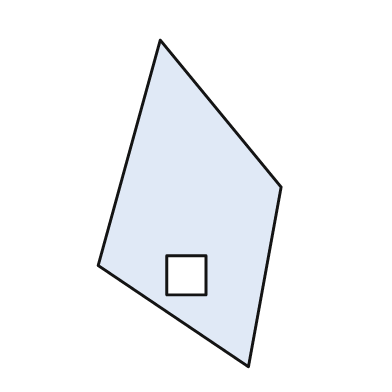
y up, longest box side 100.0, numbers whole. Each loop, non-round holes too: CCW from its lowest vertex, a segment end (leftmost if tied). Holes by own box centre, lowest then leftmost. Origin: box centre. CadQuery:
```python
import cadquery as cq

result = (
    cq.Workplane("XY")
    .moveTo(18.0, -50.0)
    .lineTo(28.0, 5.0)
    .lineTo(-9.0, 50.0)
    .lineTo(-28.0, -19.0)
    .close()
    .moveTo(-7.0, -28.0)
    .lineTo(5.0, -28.0)
    .lineTo(5.0, -16.0)
    .lineTo(-7.0, -16.0)
    .close()
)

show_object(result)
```